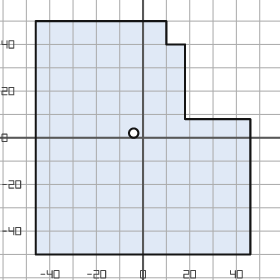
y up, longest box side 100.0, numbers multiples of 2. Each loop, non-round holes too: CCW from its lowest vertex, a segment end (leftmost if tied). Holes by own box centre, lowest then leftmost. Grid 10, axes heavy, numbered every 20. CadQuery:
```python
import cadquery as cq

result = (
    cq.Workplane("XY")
    .moveTo(-46.0, -50.0)
    .lineTo(46.0, -50.0)
    .lineTo(46.0, 8.0)
    .lineTo(18.0, 8.0)
    .lineTo(18.0, 40.0)
    .lineTo(10.0, 40.0)
    .lineTo(10.0, 50.0)
    .lineTo(-46.0, 50.0)
    .close()
    .moveTo(-4.0, 2.0)
    .circle(2.0)
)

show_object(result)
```